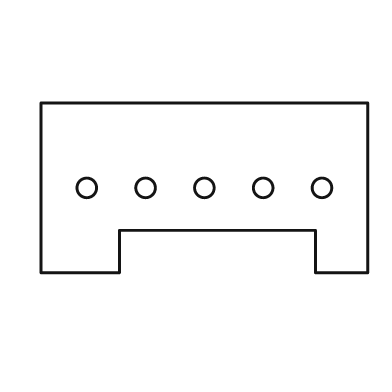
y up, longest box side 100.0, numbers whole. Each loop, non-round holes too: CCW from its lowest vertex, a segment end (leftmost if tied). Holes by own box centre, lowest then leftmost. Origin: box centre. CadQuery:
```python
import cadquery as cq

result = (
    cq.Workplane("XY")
    .moveTo(-50.0, -26.0)
    .lineTo(-26.0, -26.0)
    .lineTo(-26.0, -13.0)
    .lineTo(34.0, -13.0)
    .lineTo(34.0, -26.0)
    .lineTo(50.0, -26.0)
    .lineTo(50.0, 26.0)
    .lineTo(-50.0, 26.0)
    .close()
    .moveTo(-36.0, 0.0)
    .circle(3.0)
    .moveTo(-18.0, 0.0)
    .circle(3.0)
    .moveTo(0.0, 0.0)
    .circle(3.0)
    .moveTo(18.0, 0.0)
    .circle(3.0)
    .moveTo(36.0, 0.0)
    .circle(3.0)
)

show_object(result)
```